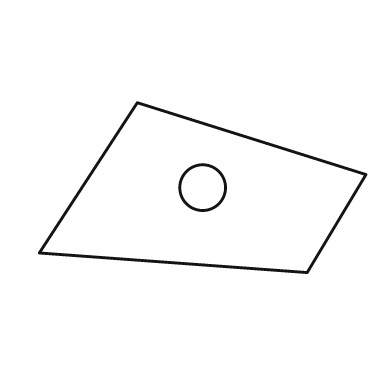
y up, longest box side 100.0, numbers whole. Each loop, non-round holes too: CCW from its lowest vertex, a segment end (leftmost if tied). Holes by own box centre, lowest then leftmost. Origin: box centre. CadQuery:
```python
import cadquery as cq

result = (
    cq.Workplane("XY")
    .moveTo(32.0, -26.0)
    .lineTo(50.0, 4.0)
    .lineTo(-20.0, 26.0)
    .lineTo(-50.0, -20.0)
    .close()
    .moveTo(0.0, 0.0)
    .circle(7.0)
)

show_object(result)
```